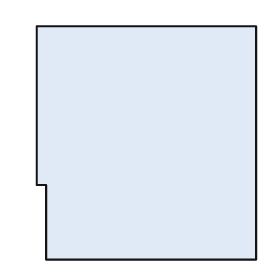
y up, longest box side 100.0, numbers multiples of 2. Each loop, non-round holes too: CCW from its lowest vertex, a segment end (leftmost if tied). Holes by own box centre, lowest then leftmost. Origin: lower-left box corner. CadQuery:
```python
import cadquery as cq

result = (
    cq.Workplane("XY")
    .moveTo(4.0, 0.0)
    .lineTo(94.0, 0.0)
    .lineTo(94.0, 100.0)
    .lineTo(0.0, 100.0)
    .lineTo(0.0, 32.0)
    .lineTo(4.0, 32.0)
    .close()
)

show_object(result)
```